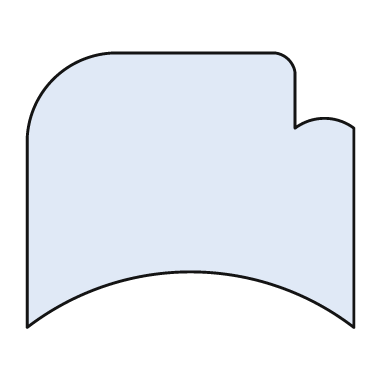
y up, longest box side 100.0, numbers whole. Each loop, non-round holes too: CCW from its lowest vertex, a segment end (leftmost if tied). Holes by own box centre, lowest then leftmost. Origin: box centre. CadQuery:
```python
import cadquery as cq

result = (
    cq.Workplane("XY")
    .moveTo(-50.0, -42.0)
    .threePointArc((0.0, -25.0), (50.0, -42.0))
    .lineTo(50.0, 19.0)
    .threePointArc((41.0, 22.0), (32.0, 19.0))
    .lineTo(32.0, 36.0)
    .threePointArc((30.0, 40.0), (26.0, 42.0))
    .lineTo(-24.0, 42.0)
    .threePointArc((-42.0, 34.0), (-50.0, 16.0))
    .close()
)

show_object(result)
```